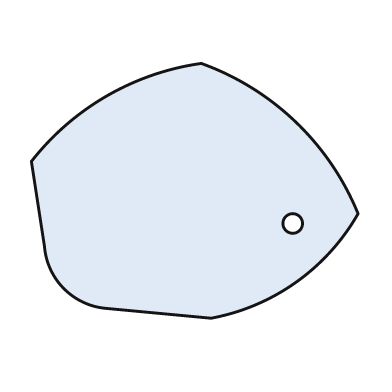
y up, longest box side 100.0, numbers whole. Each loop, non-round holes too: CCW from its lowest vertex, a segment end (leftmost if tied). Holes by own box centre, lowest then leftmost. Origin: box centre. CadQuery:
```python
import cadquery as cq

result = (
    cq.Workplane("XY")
    .moveTo(5.0, -39.0)
    .threePointArc((31.0, -28.0), (50.0, -7.0))
    .threePointArc((31.0, 21.0), (2.0, 39.0))
    .threePointArc((-27.0, 29.0), (-50.0, 9.0))
    .lineTo(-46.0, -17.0)
    .threePointArc((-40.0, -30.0), (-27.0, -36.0))
    .close()
    .moveTo(30.0, -10.0)
    .circle(3.0)
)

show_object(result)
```